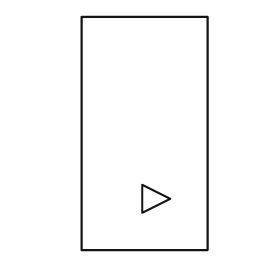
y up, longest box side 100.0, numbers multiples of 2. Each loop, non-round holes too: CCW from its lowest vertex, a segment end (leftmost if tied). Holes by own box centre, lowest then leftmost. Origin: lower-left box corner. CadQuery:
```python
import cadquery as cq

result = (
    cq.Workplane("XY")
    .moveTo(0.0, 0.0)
    .lineTo(54.0, 0.0)
    .lineTo(54.0, 100.0)
    .lineTo(0.0, 100.0)
    .close()
    .moveTo(26.0, 16.0)
    .lineTo(38.0, 22.0)
    .lineTo(26.0, 28.0)
    .close()
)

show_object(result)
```